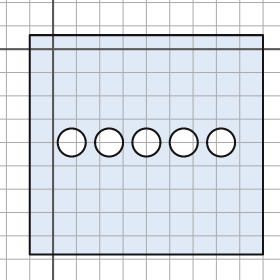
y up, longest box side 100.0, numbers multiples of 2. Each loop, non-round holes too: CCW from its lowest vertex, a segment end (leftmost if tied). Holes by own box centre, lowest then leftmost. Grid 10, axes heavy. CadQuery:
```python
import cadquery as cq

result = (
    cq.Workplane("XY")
    .moveTo(-10.0, -88.0)
    .lineTo(90.0, -88.0)
    .lineTo(90.0, 6.0)
    .lineTo(-10.0, 6.0)
    .close()
    .moveTo(8.0, -40.0)
    .circle(6.0)
    .moveTo(24.0, -40.0)
    .circle(6.0)
    .moveTo(40.0, -40.0)
    .circle(6.0)
    .moveTo(56.0, -40.0)
    .circle(6.0)
    .moveTo(72.0, -40.0)
    .circle(6.0)
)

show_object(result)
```